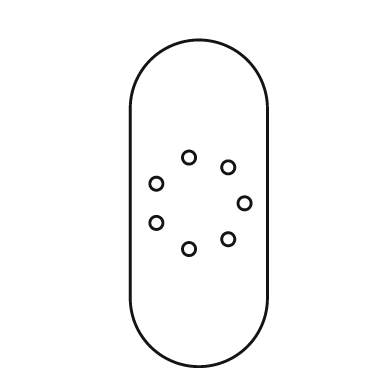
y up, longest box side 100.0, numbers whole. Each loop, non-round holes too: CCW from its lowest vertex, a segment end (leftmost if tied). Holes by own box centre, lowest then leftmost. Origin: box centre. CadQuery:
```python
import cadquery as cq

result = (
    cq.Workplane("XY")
    .moveTo(-21.0, -29.0)
    .threePointArc((0.0, -50.0), (21.0, -29.0))
    .lineTo(21.0, 29.0)
    .threePointArc((0.0, 50.0), (-21.0, 29.0))
    .close()
    .moveTo(-3.0, -14.0)
    .circle(2.0)
    .moveTo(9.0, -11.0)
    .circle(2.0)
    .moveTo(-13.0, -6.0)
    .circle(2.0)
    .moveTo(14.0, 0.0)
    .circle(2.0)
    .moveTo(-13.0, 6.0)
    .circle(2.0)
    .moveTo(9.0, 11.0)
    .circle(2.0)
    .moveTo(-3.0, 14.0)
    .circle(2.0)
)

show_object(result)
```